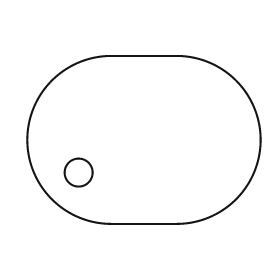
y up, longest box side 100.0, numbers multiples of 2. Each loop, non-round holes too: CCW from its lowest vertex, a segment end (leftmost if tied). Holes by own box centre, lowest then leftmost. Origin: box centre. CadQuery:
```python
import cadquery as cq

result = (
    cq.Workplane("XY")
    .moveTo(-14.0, -36.0)
    .lineTo(14.0, -36.0)
    .threePointArc((50.0, 0.0), (14.0, 36.0))
    .lineTo(-14.0, 36.0)
    .threePointArc((-50.0, 0.0), (-14.0, -36.0))
    .close()
    .moveTo(-28.0, -14.0)
    .circle(6.0)
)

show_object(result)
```